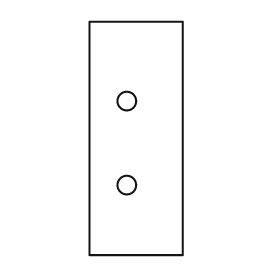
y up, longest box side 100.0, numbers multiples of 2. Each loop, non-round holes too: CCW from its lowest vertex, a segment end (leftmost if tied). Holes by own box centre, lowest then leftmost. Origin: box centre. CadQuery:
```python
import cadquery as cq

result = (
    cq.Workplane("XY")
    .moveTo(-20.0, -50.0)
    .lineTo(20.0, -50.0)
    .lineTo(20.0, 50.0)
    .lineTo(-20.0, 50.0)
    .close()
    .moveTo(-4.0, -20.0)
    .circle(4.0)
    .moveTo(-4.0, 16.0)
    .circle(4.0)
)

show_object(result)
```